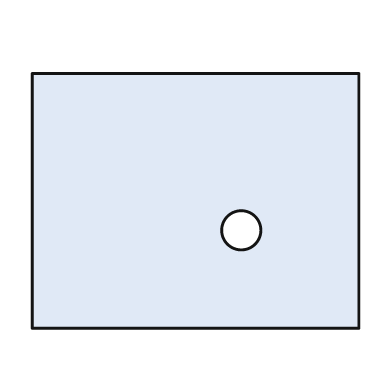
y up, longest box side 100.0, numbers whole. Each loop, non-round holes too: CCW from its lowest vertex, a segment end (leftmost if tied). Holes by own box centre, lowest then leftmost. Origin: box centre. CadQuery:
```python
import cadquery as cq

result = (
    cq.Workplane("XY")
    .moveTo(-50.0, -39.0)
    .lineTo(50.0, -39.0)
    .lineTo(50.0, 39.0)
    .lineTo(-50.0, 39.0)
    .close()
    .moveTo(14.0, -9.0)
    .circle(6.0)
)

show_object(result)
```